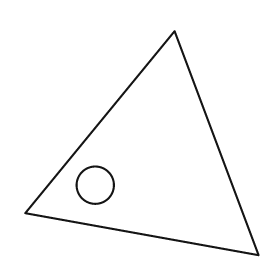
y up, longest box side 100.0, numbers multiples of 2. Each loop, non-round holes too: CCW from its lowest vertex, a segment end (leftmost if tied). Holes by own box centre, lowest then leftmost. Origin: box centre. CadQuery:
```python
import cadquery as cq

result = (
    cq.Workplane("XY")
    .moveTo(50.0, -48.0)
    .lineTo(14.0, 48.0)
    .lineTo(-50.0, -30.0)
    .close()
    .moveTo(-20.0, -18.0)
    .circle(8.0)
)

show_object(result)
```